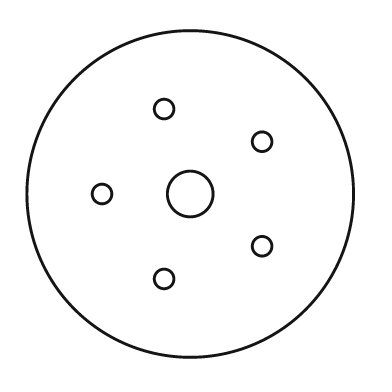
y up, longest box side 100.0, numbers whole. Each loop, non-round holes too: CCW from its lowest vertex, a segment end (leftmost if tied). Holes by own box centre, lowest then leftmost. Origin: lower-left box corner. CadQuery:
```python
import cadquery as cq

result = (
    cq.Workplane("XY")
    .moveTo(50.0, 50.0)
    .circle(50.0)
    .moveTo(42.0, 24.0)
    .circle(3.0)
    .moveTo(72.0, 34.0)
    .circle(3.0)
    .moveTo(23.0, 50.0)
    .circle(3.0)
    .moveTo(50.0, 50.0)
    .circle(7.0)
    .moveTo(72.0, 66.0)
    .circle(3.0)
    .moveTo(42.0, 76.0)
    .circle(3.0)
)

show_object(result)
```